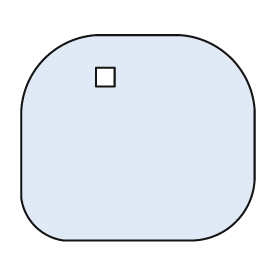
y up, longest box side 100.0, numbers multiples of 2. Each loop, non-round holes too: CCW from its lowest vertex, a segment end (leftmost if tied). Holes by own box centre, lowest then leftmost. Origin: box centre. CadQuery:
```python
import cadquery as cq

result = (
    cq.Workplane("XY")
    .moveTo(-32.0, -44.0)
    .lineTo(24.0, -44.0)
    .threePointArc((42.0, -36.0), (50.0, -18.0))
    .lineTo(50.0, 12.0)
    .threePointArc((40.0, 34.0), (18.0, 44.0))
    .lineTo(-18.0, 44.0)
    .threePointArc((-40.0, 34.0), (-50.0, 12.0))
    .lineTo(-50.0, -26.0)
    .threePointArc((-44.0, -38.0), (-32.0, -44.0))
    .close()
    .moveTo(-18.0, 22.0)
    .lineTo(-10.0, 22.0)
    .lineTo(-10.0, 30.0)
    .lineTo(-18.0, 30.0)
    .close()
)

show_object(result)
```